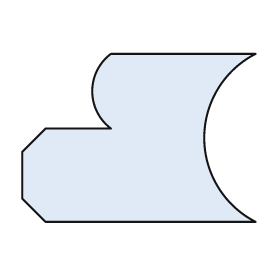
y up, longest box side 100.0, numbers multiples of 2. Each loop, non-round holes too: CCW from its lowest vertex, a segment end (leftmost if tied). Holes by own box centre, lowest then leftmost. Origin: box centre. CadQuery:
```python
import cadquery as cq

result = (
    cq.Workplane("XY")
    .moveTo(-40.0, -36.0)
    .lineTo(50.0, -36.0)
    .threePointArc((28.0, 0.0), (50.0, 36.0))
    .lineTo(-12.0, 36.0)
    .threePointArc((-20.0, 20.0), (-12.0, 4.0))
    .lineTo(-40.0, 4.0)
    .lineTo(-50.0, -6.0)
    .lineTo(-50.0, -26.0)
    .close()
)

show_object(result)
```